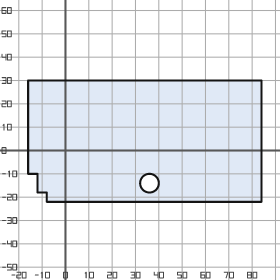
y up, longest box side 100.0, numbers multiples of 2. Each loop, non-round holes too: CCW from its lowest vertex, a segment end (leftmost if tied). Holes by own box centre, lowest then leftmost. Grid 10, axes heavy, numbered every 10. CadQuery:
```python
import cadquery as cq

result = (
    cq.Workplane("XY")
    .moveTo(-8.0, -22.0)
    .lineTo(84.0, -22.0)
    .lineTo(84.0, 30.0)
    .lineTo(-16.0, 30.0)
    .lineTo(-16.0, -10.0)
    .lineTo(-12.0, -10.0)
    .lineTo(-12.0, -18.0)
    .lineTo(-8.0, -18.0)
    .close()
    .moveTo(36.0, -14.0)
    .circle(4.0)
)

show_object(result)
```